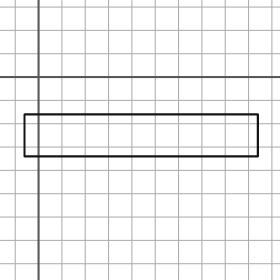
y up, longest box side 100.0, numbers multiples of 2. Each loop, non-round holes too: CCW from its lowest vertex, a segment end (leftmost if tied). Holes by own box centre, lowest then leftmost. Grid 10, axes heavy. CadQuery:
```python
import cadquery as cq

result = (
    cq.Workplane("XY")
    .moveTo(-6.0, -34.0)
    .lineTo(94.0, -34.0)
    .lineTo(94.0, -16.0)
    .lineTo(-6.0, -16.0)
    .close()
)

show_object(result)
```